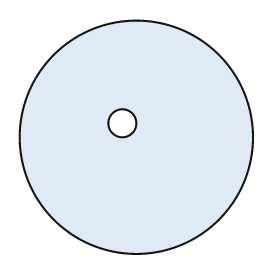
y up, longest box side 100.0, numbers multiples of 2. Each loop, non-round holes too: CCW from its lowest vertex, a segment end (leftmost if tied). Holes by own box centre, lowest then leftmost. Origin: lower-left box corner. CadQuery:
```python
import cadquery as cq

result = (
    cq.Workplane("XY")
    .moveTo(50.0, 50.0)
    .circle(50.0)
    .moveTo(44.0, 56.0)
    .circle(6.0)
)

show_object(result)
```